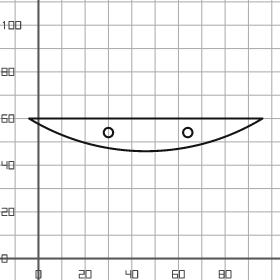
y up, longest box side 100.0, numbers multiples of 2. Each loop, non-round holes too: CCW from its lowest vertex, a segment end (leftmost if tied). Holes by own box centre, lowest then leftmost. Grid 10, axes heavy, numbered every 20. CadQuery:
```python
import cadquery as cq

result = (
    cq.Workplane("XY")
    .moveTo(-4.0, 60.0)
    .threePointArc((46.0, 46.0), (96.0, 60.0))
    .close()
    .moveTo(30.0, 54.0)
    .circle(2.0)
    .moveTo(64.0, 54.0)
    .circle(2.0)
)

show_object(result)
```